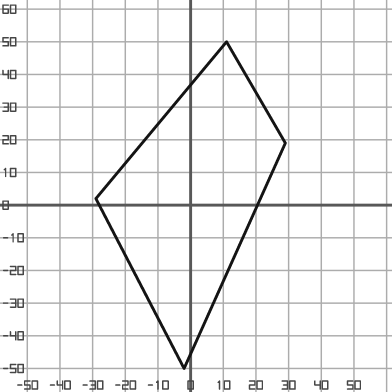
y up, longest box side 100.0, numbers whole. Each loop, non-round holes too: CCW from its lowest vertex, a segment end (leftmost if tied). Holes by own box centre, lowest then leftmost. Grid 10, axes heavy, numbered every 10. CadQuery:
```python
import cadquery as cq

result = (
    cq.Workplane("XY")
    .moveTo(-2.0, -50.0)
    .lineTo(29.0, 19.0)
    .lineTo(11.0, 50.0)
    .lineTo(-29.0, 2.0)
    .close()
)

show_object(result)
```